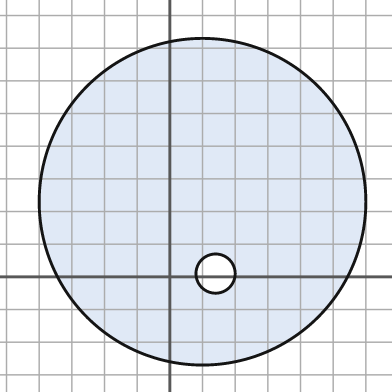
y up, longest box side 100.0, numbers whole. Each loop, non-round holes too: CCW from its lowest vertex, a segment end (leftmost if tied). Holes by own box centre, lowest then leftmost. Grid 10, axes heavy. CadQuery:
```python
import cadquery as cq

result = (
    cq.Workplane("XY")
    .moveTo(10.0, 23.0)
    .circle(50.0)
    .moveTo(14.0, 1.0)
    .circle(6.0)
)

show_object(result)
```